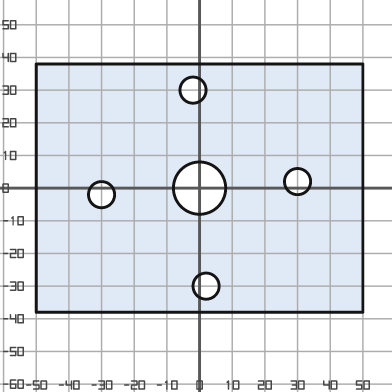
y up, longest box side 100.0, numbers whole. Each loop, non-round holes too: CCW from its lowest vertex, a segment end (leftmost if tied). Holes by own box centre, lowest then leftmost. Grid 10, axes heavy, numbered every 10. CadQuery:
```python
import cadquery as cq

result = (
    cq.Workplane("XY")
    .moveTo(-50.0, -38.0)
    .lineTo(50.0, -38.0)
    .lineTo(50.0, 38.0)
    .lineTo(-50.0, 38.0)
    .close()
    .moveTo(2.0, -30.0)
    .circle(4.0)
    .moveTo(-30.0, -2.0)
    .circle(4.0)
    .moveTo(0.0, 0.0)
    .circle(8.0)
    .moveTo(30.0, 2.0)
    .circle(4.0)
    .moveTo(-2.0, 30.0)
    .circle(4.0)
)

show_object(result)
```